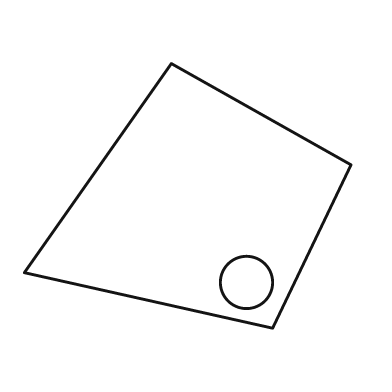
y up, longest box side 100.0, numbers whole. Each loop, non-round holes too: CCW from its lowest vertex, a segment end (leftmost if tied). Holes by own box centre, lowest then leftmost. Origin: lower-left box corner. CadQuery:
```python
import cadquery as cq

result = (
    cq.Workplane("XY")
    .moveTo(76.0, 0.0)
    .lineTo(100.0, 50.0)
    .lineTo(45.0, 81.0)
    .lineTo(0.0, 17.0)
    .close()
    .moveTo(68.0, 14.0)
    .circle(8.0)
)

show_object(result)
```